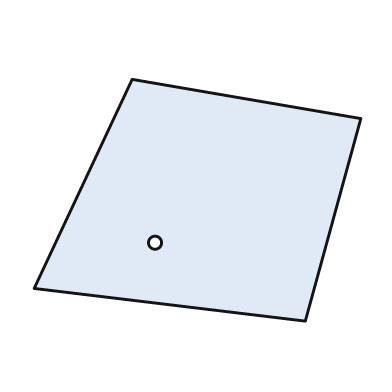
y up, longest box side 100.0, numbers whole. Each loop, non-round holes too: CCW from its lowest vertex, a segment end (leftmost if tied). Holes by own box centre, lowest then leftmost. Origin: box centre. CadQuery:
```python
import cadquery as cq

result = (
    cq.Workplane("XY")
    .moveTo(33.0, -37.0)
    .lineTo(50.0, 25.0)
    .lineTo(-20.0, 37.0)
    .lineTo(-50.0, -27.0)
    .close()
    .moveTo(-13.0, -13.0)
    .circle(2.0)
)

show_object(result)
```